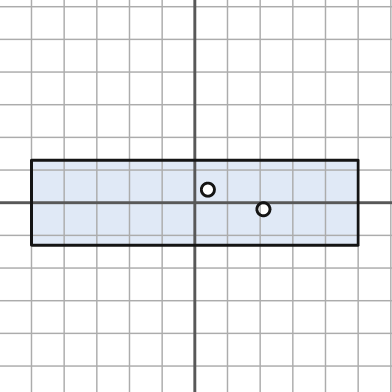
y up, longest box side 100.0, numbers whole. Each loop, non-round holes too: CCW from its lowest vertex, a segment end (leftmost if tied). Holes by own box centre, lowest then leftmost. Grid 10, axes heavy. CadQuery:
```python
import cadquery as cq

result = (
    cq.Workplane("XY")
    .moveTo(-50.0, -13.0)
    .lineTo(50.0, -13.0)
    .lineTo(50.0, 13.0)
    .lineTo(-50.0, 13.0)
    .close()
    .moveTo(21.0, -2.0)
    .circle(2.0)
    .moveTo(4.0, 4.0)
    .circle(2.0)
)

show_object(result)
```